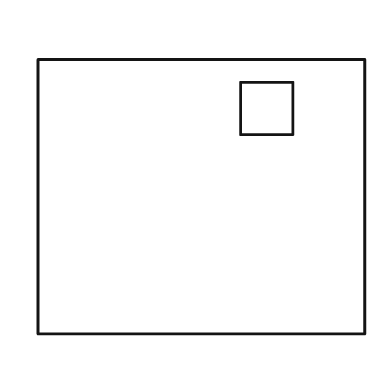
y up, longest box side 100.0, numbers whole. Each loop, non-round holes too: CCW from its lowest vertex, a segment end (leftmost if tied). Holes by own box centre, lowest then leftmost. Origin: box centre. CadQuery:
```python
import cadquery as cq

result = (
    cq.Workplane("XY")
    .moveTo(-50.0, -42.0)
    .lineTo(50.0, -42.0)
    .lineTo(50.0, 42.0)
    .lineTo(-50.0, 42.0)
    .close()
    .moveTo(12.0, 19.0)
    .lineTo(28.0, 19.0)
    .lineTo(28.0, 35.0)
    .lineTo(12.0, 35.0)
    .close()
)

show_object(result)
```